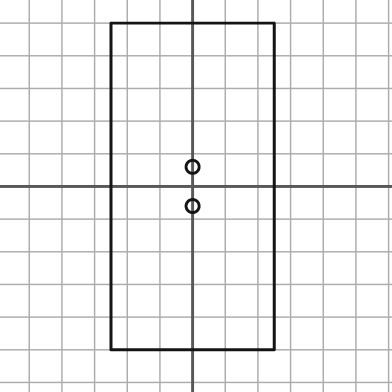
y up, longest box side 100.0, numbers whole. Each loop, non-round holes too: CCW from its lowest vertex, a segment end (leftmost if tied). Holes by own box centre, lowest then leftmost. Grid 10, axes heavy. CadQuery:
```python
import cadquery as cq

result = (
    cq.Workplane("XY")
    .moveTo(-25.0, -50.0)
    .lineTo(25.0, -50.0)
    .lineTo(25.0, 50.0)
    .lineTo(-25.0, 50.0)
    .close()
    .moveTo(0.0, -6.0)
    .circle(2.0)
    .moveTo(0.0, 6.0)
    .circle(2.0)
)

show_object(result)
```